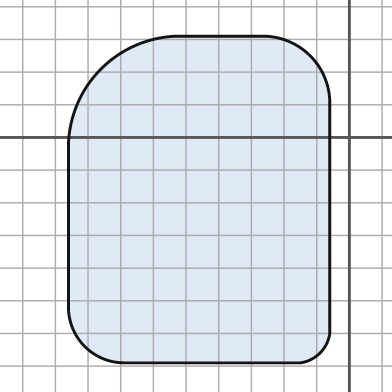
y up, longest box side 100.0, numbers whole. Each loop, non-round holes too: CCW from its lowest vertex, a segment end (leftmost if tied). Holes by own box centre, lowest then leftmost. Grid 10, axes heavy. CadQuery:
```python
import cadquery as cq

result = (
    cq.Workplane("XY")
    .moveTo(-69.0, -69.0)
    .lineTo(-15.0, -69.0)
    .threePointArc((-9.0, -66.0), (-6.0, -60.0))
    .lineTo(-6.0, 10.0)
    .threePointArc((-12.0, 25.0), (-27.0, 31.0))
    .lineTo(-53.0, 31.0)
    .threePointArc((-76.0, 21.0), (-86.0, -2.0))
    .lineTo(-86.0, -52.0)
    .threePointArc((-81.0, -64.0), (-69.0, -69.0))
    .close()
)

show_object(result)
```